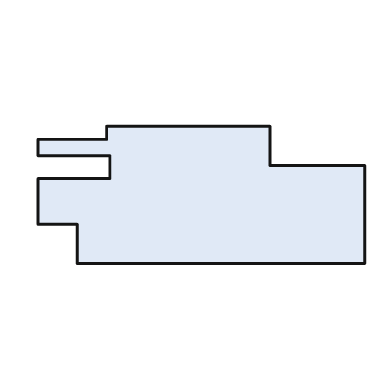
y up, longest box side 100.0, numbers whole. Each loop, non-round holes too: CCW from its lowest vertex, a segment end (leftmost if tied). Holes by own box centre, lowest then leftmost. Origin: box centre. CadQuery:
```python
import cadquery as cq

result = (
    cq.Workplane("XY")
    .moveTo(-38.0, -21.0)
    .lineTo(50.0, -21.0)
    .lineTo(50.0, 9.0)
    .lineTo(21.0, 9.0)
    .lineTo(21.0, 21.0)
    .lineTo(-29.0, 21.0)
    .lineTo(-29.0, 17.0)
    .lineTo(-50.0, 17.0)
    .lineTo(-50.0, 12.0)
    .lineTo(-28.0, 12.0)
    .lineTo(-28.0, 5.0)
    .lineTo(-50.0, 5.0)
    .lineTo(-50.0, -9.0)
    .lineTo(-38.0, -9.0)
    .close()
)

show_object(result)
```